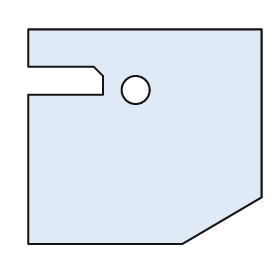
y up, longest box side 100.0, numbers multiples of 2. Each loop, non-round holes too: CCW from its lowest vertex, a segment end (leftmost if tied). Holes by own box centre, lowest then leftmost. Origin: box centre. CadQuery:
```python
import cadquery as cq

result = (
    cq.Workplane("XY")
    .moveTo(-50.0, -46.0)
    .lineTo(16.0, -46.0)
    .lineTo(50.0, -26.0)
    .lineTo(50.0, 46.0)
    .lineTo(-50.0, 46.0)
    .lineTo(-50.0, 30.0)
    .lineTo(-22.0, 30.0)
    .lineTo(-18.0, 26.0)
    .lineTo(-18.0, 18.0)
    .lineTo(-50.0, 18.0)
    .close()
    .moveTo(-4.0, 20.0)
    .circle(6.0)
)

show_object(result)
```